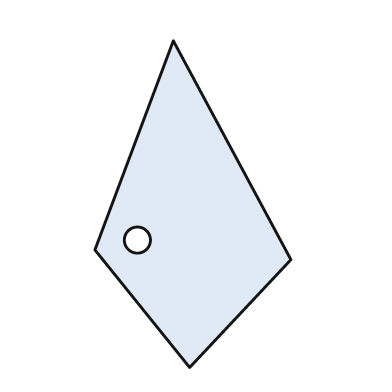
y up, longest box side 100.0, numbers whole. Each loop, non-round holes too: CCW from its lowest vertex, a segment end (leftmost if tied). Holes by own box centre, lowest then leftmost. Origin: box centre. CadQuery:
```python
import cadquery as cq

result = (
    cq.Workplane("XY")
    .moveTo(-1.0, -50.0)
    .lineTo(30.0, -17.0)
    .lineTo(-6.0, 50.0)
    .lineTo(-30.0, -14.0)
    .close()
    .moveTo(-17.0, -11.0)
    .circle(4.0)
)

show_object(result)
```